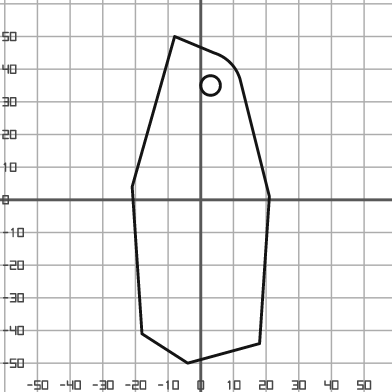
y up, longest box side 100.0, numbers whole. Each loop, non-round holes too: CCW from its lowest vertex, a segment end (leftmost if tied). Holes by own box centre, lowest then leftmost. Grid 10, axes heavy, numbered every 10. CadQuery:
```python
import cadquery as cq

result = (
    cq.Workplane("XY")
    .moveTo(-4.0, -50.0)
    .lineTo(18.0, -44.0)
    .lineTo(21.0, 1.0)
    .lineTo(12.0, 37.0)
    .threePointArc((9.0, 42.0), (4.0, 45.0))
    .lineTo(-8.0, 50.0)
    .lineTo(-21.0, 4.0)
    .lineTo(-18.0, -41.0)
    .close()
    .moveTo(3.0, 35.0)
    .circle(3.0)
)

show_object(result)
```